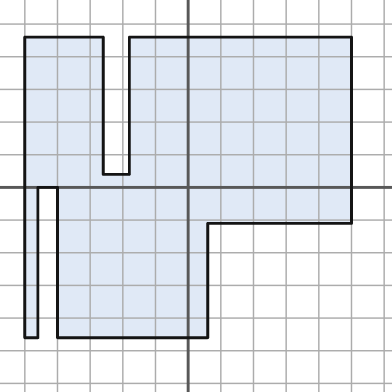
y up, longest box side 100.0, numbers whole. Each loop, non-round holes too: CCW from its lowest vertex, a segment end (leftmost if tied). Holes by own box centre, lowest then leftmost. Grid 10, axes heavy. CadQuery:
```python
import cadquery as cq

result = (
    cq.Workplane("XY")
    .moveTo(-50.0, -46.0)
    .lineTo(-46.0, -46.0)
    .lineTo(-46.0, 0.0)
    .lineTo(-40.0, 0.0)
    .lineTo(-40.0, -46.0)
    .lineTo(6.0, -46.0)
    .lineTo(6.0, -11.0)
    .lineTo(50.0, -11.0)
    .lineTo(50.0, 46.0)
    .lineTo(-18.0, 46.0)
    .lineTo(-18.0, 4.0)
    .lineTo(-26.0, 4.0)
    .lineTo(-26.0, 46.0)
    .lineTo(-50.0, 46.0)
    .close()
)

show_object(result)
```